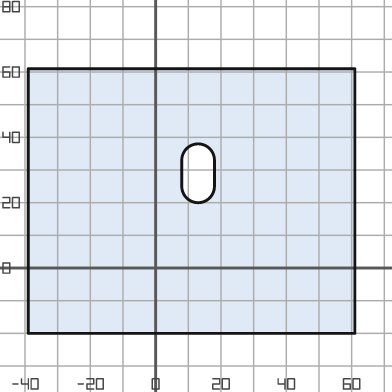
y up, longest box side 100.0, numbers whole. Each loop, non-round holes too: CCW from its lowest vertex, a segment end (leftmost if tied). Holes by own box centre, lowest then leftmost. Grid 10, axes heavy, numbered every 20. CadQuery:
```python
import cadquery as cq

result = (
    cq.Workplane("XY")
    .moveTo(-39.0, -20.0)
    .lineTo(61.0, -20.0)
    .lineTo(61.0, 61.0)
    .lineTo(-39.0, 61.0)
    .close()
    .moveTo(8.0, 25.0)
    .threePointArc((13.0, 20.0), (18.0, 25.0))
    .lineTo(18.0, 33.0)
    .threePointArc((13.0, 38.0), (8.0, 33.0))
    .close()
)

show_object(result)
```